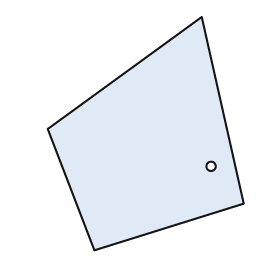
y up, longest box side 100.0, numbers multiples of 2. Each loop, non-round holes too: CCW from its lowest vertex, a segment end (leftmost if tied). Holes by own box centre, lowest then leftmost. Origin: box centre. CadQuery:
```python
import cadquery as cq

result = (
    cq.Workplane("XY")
    .moveTo(-22.0, -50.0)
    .lineTo(42.0, -30.0)
    .lineTo(24.0, 50.0)
    .lineTo(-42.0, 2.0)
    .close()
    .moveTo(28.0, -14.0)
    .circle(2.0)
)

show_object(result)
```